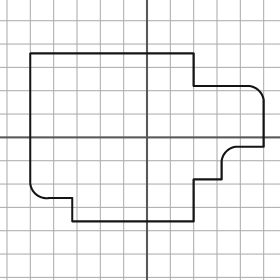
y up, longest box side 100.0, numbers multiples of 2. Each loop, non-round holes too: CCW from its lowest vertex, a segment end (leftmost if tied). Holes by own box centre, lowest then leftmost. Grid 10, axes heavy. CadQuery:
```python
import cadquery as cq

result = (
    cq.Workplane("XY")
    .moveTo(-32.0, -36.0)
    .lineTo(20.0, -36.0)
    .lineTo(20.0, -18.0)
    .lineTo(32.0, -18.0)
    .lineTo(32.0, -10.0)
    .threePointArc((34.0, -6.0), (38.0, -4.0))
    .lineTo(50.0, -4.0)
    .lineTo(50.0, 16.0)
    .threePointArc((48.0, 20.0), (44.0, 22.0))
    .lineTo(20.0, 22.0)
    .lineTo(20.0, 36.0)
    .lineTo(-50.0, 36.0)
    .lineTo(-50.0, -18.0)
    .threePointArc((-48.0, -24.0), (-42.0, -26.0))
    .lineTo(-32.0, -26.0)
    .close()
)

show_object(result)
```